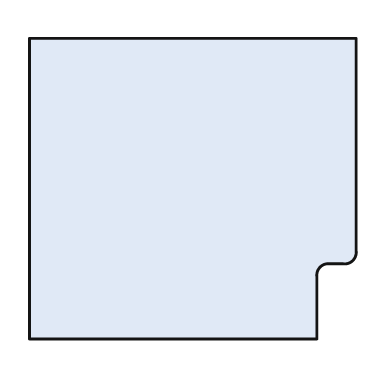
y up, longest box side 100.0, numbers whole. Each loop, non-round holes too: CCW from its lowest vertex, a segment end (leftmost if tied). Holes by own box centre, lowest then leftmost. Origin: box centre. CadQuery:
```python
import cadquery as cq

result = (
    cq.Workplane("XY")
    .moveTo(-50.0, -46.0)
    .lineTo(38.0, -46.0)
    .lineTo(38.0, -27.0)
    .threePointArc((39.0, -24.0), (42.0, -23.0))
    .lineTo(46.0, -23.0)
    .threePointArc((49.0, -22.0), (50.0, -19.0))
    .lineTo(50.0, 46.0)
    .lineTo(-50.0, 46.0)
    .close()
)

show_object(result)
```